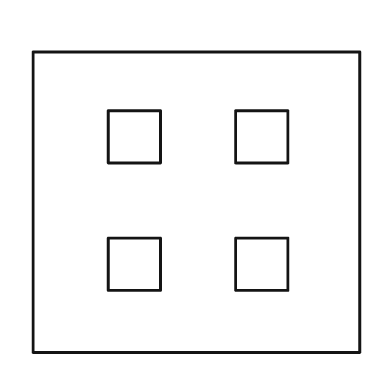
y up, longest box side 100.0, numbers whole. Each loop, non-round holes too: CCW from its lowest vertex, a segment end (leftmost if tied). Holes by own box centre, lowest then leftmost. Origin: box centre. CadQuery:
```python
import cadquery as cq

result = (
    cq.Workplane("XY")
    .moveTo(-50.0, -46.0)
    .lineTo(50.0, -46.0)
    .lineTo(50.0, 46.0)
    .lineTo(-50.0, 46.0)
    .close()
    .moveTo(-27.0, -27.0)
    .lineTo(-11.0, -27.0)
    .lineTo(-11.0, -11.0)
    .lineTo(-27.0, -11.0)
    .close()
    .moveTo(12.0, -27.0)
    .lineTo(28.0, -27.0)
    .lineTo(28.0, -11.0)
    .lineTo(12.0, -11.0)
    .close()
    .moveTo(-27.0, 12.0)
    .lineTo(-11.0, 12.0)
    .lineTo(-11.0, 28.0)
    .lineTo(-27.0, 28.0)
    .close()
    .moveTo(12.0, 12.0)
    .lineTo(28.0, 12.0)
    .lineTo(28.0, 28.0)
    .lineTo(12.0, 28.0)
    .close()
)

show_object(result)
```